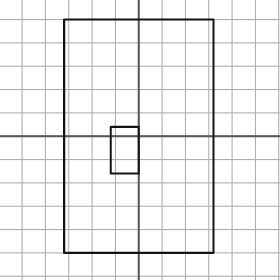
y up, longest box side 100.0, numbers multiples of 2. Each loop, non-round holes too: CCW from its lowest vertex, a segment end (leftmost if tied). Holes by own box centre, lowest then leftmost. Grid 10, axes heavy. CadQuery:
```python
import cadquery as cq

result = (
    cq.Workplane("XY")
    .moveTo(-32.0, -50.0)
    .lineTo(32.0, -50.0)
    .lineTo(32.0, 50.0)
    .lineTo(-32.0, 50.0)
    .close()
    .moveTo(-12.0, -16.0)
    .lineTo(0.0, -16.0)
    .lineTo(0.0, 4.0)
    .lineTo(-12.0, 4.0)
    .close()
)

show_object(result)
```